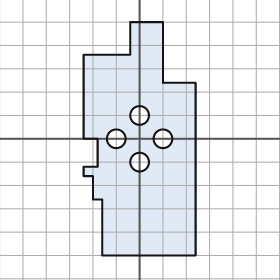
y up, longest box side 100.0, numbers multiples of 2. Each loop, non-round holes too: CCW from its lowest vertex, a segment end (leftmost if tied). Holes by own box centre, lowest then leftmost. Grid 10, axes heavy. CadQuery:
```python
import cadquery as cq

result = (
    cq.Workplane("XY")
    .moveTo(-16.0, -50.0)
    .lineTo(24.0, -50.0)
    .lineTo(24.0, 24.0)
    .lineTo(10.0, 24.0)
    .lineTo(10.0, 50.0)
    .lineTo(-4.0, 50.0)
    .lineTo(-4.0, 36.0)
    .lineTo(-24.0, 36.0)
    .lineTo(-24.0, 0.0)
    .lineTo(-18.0, 0.0)
    .lineTo(-18.0, -12.0)
    .lineTo(-24.0, -12.0)
    .lineTo(-24.0, -16.0)
    .lineTo(-20.0, -16.0)
    .lineTo(-20.0, -26.0)
    .lineTo(-16.0, -26.0)
    .close()
    .moveTo(0.0, -10.0)
    .circle(4.0)
    .moveTo(-10.0, 0.0)
    .circle(4.0)
    .moveTo(10.0, 0.0)
    .circle(4.0)
    .moveTo(0.0, 10.0)
    .circle(4.0)
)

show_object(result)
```